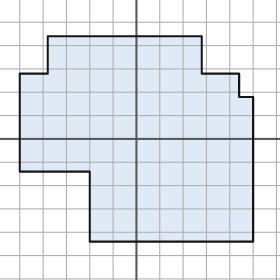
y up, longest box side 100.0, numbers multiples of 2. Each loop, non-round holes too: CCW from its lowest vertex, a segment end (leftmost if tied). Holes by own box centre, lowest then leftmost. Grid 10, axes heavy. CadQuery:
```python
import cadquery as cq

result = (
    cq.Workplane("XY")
    .moveTo(-20.0, -44.0)
    .lineTo(50.0, -44.0)
    .lineTo(50.0, 18.0)
    .lineTo(44.0, 18.0)
    .lineTo(44.0, 28.0)
    .lineTo(28.0, 28.0)
    .lineTo(28.0, 44.0)
    .lineTo(-38.0, 44.0)
    .lineTo(-38.0, 28.0)
    .lineTo(-50.0, 28.0)
    .lineTo(-50.0, -14.0)
    .lineTo(-20.0, -14.0)
    .close()
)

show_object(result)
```